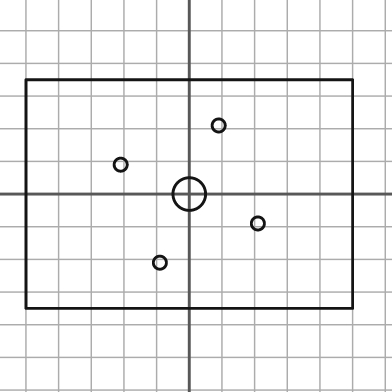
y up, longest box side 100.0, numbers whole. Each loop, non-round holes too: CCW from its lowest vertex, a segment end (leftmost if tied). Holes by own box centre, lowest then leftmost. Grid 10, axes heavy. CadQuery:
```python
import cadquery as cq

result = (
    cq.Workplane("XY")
    .moveTo(-50.0, -35.0)
    .lineTo(50.0, -35.0)
    .lineTo(50.0, 35.0)
    .lineTo(-50.0, 35.0)
    .close()
    .moveTo(-9.0, -21.0)
    .circle(2.0)
    .moveTo(21.0, -9.0)
    .circle(2.0)
    .moveTo(0.0, 0.0)
    .circle(5.0)
    .moveTo(-21.0, 9.0)
    .circle(2.0)
    .moveTo(9.0, 21.0)
    .circle(2.0)
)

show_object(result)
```